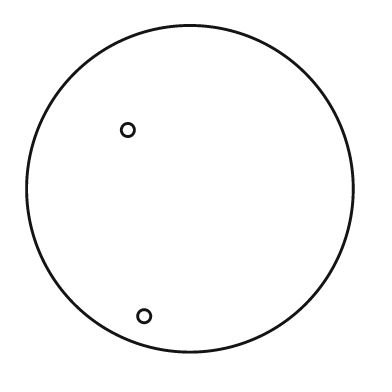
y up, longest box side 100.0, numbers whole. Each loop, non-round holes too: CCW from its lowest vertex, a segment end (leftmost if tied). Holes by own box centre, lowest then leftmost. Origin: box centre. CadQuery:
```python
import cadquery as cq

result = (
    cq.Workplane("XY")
    .moveTo(0.0, 0.0)
    .circle(50.0)
    .moveTo(-14.0, -39.0)
    .circle(2.0)
    .moveTo(-19.0, 18.0)
    .circle(2.0)
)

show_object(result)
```